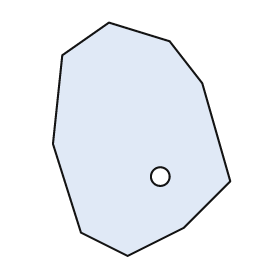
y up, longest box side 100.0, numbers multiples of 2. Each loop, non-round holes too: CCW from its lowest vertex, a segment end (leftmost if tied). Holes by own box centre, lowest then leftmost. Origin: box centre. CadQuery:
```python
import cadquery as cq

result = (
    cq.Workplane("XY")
    .moveTo(-6.0, -50.0)
    .lineTo(18.0, -38.0)
    .lineTo(38.0, -18.0)
    .lineTo(26.0, 24.0)
    .lineTo(12.0, 42.0)
    .lineTo(-14.0, 50.0)
    .lineTo(-34.0, 36.0)
    .lineTo(-38.0, -2.0)
    .lineTo(-26.0, -40.0)
    .close()
    .moveTo(8.0, -16.0)
    .circle(4.0)
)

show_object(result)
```